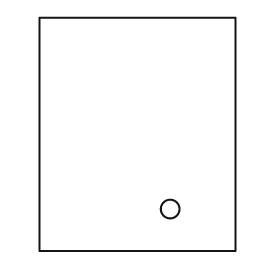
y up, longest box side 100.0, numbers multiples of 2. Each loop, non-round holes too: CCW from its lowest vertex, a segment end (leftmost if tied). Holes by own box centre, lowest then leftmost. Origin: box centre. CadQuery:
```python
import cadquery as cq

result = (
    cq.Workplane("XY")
    .moveTo(-42.0, -50.0)
    .lineTo(42.0, -50.0)
    .lineTo(42.0, 50.0)
    .lineTo(-42.0, 50.0)
    .close()
    .moveTo(14.0, -32.0)
    .circle(4.0)
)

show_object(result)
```